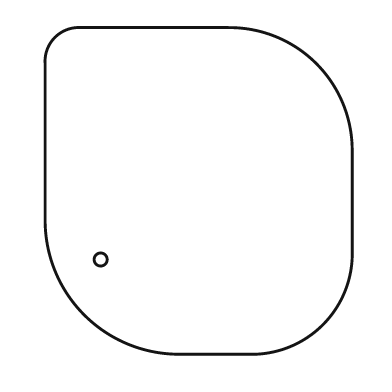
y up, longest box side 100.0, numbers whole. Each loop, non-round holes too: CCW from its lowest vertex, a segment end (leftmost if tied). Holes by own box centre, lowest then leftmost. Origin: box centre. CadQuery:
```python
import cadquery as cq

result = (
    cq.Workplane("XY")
    .moveTo(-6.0, -50.0)
    .lineTo(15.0, -50.0)
    .threePointArc((38.0, -41.0), (47.0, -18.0))
    .lineTo(47.0, 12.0)
    .threePointArc((36.0, 39.0), (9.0, 50.0))
    .lineTo(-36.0, 50.0)
    .threePointArc((-44.0, 47.0), (-47.0, 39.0))
    .lineTo(-47.0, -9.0)
    .threePointArc((-35.0, -38.0), (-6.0, -50.0))
    .close()
    .moveTo(-30.0, -21.0)
    .circle(2.0)
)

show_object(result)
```